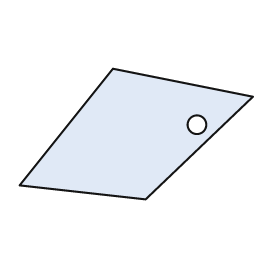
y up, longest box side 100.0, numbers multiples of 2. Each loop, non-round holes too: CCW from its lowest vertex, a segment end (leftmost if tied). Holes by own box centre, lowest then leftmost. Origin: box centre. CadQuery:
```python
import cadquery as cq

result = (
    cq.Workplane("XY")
    .moveTo(4.0, -28.0)
    .lineTo(50.0, 16.0)
    .lineTo(-10.0, 28.0)
    .lineTo(-50.0, -22.0)
    .close()
    .moveTo(26.0, 4.0)
    .circle(4.0)
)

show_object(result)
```